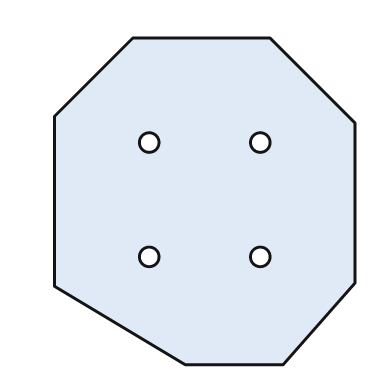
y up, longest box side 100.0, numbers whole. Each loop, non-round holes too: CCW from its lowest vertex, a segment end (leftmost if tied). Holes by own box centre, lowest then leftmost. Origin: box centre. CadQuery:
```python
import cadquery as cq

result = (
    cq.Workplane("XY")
    .moveTo(-6.0, -50.0)
    .lineTo(24.0, -50.0)
    .lineTo(46.0, -25.0)
    .lineTo(46.0, 24.0)
    .lineTo(20.0, 50.0)
    .lineTo(-22.0, 50.0)
    .lineTo(-46.0, 26.0)
    .lineTo(-46.0, -26.0)
    .close()
    .moveTo(-17.0, -17.0)
    .circle(3.0)
    .moveTo(17.0, -17.0)
    .circle(3.0)
    .moveTo(-17.0, 18.0)
    .circle(3.0)
    .moveTo(17.0, 18.0)
    .circle(3.0)
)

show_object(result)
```